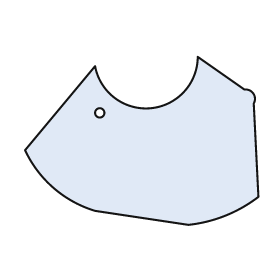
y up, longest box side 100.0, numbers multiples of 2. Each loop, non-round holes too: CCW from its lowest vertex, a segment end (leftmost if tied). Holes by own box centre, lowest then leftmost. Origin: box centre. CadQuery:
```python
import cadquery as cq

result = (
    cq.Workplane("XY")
    .moveTo(20.0, -36.0)
    .threePointArc((36.0, -32.0), (50.0, -24.0))
    .lineTo(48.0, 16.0)
    .threePointArc((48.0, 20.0), (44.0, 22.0))
    .lineTo(24.0, 36.0)
    .threePointArc((4.0, 14.0), (-20.0, 32.0))
    .lineTo(-50.0, -4.0)
    .threePointArc((-38.0, -20.0), (-20.0, -30.0))
    .close()
    .moveTo(-18.0, 12.0)
    .circle(2.0)
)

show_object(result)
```